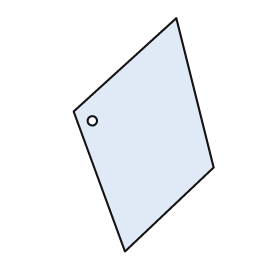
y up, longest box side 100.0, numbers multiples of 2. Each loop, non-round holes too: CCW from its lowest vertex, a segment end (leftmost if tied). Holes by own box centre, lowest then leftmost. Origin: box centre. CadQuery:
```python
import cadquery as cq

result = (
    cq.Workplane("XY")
    .moveTo(-8.0, -50.0)
    .lineTo(30.0, -14.0)
    .lineTo(14.0, 50.0)
    .lineTo(-30.0, 10.0)
    .close()
    .moveTo(-22.0, 6.0)
    .circle(2.0)
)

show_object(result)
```